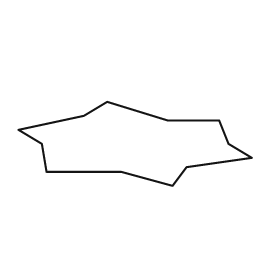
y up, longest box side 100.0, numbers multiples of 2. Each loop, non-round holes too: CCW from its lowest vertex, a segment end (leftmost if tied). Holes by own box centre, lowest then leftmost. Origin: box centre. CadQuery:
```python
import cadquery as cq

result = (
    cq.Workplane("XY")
    .moveTo(16.0, -18.0)
    .lineTo(22.0, -10.0)
    .lineTo(50.0, -6.0)
    .lineTo(40.0, 0.0)
    .lineTo(36.0, 10.0)
    .lineTo(14.0, 10.0)
    .lineTo(-12.0, 18.0)
    .lineTo(-22.0, 12.0)
    .lineTo(-50.0, 6.0)
    .lineTo(-40.0, 0.0)
    .lineTo(-38.0, -12.0)
    .lineTo(-6.0, -12.0)
    .close()
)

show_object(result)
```